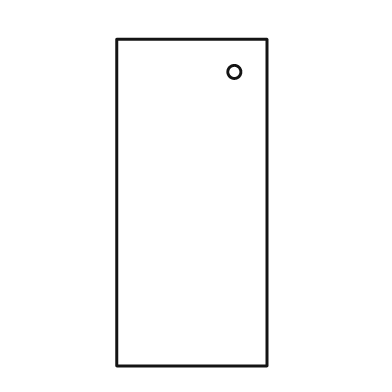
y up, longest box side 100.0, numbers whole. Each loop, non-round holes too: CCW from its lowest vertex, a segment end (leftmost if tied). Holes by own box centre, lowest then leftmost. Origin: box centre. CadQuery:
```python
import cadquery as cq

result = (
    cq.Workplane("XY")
    .moveTo(-23.0, -50.0)
    .lineTo(23.0, -50.0)
    .lineTo(23.0, 50.0)
    .lineTo(-23.0, 50.0)
    .close()
    .moveTo(13.0, 40.0)
    .circle(2.0)
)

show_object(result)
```